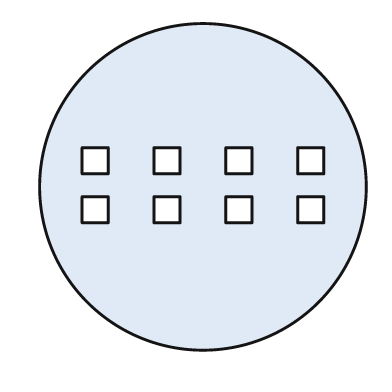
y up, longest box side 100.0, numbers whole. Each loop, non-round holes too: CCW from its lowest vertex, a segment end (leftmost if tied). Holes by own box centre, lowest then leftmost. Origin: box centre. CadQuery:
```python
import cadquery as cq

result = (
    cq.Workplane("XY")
    .moveTo(0.0, 0.0)
    .circle(50.0)
    .moveTo(-37.0, -11.0)
    .lineTo(-29.0, -11.0)
    .lineTo(-29.0, -3.0)
    .lineTo(-37.0, -3.0)
    .close()
    .moveTo(-15.0, -11.0)
    .lineTo(-7.0, -11.0)
    .lineTo(-7.0, -3.0)
    .lineTo(-15.0, -3.0)
    .close()
    .moveTo(7.0, -11.0)
    .lineTo(15.0, -11.0)
    .lineTo(15.0, -3.0)
    .lineTo(7.0, -3.0)
    .close()
    .moveTo(29.0, -11.0)
    .lineTo(37.0, -11.0)
    .lineTo(37.0, -3.0)
    .lineTo(29.0, -3.0)
    .close()
    .moveTo(-37.0, 4.0)
    .lineTo(-29.0, 4.0)
    .lineTo(-29.0, 12.0)
    .lineTo(-37.0, 12.0)
    .close()
    .moveTo(-15.0, 4.0)
    .lineTo(-7.0, 4.0)
    .lineTo(-7.0, 12.0)
    .lineTo(-15.0, 12.0)
    .close()
    .moveTo(7.0, 4.0)
    .lineTo(15.0, 4.0)
    .lineTo(15.0, 12.0)
    .lineTo(7.0, 12.0)
    .close()
    .moveTo(29.0, 4.0)
    .lineTo(37.0, 4.0)
    .lineTo(37.0, 12.0)
    .lineTo(29.0, 12.0)
    .close()
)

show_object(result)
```